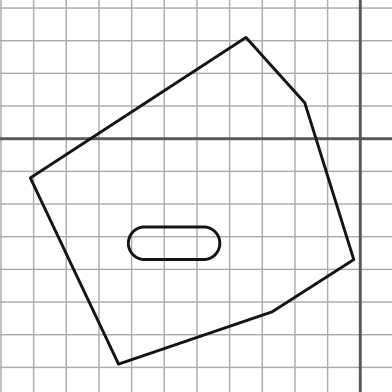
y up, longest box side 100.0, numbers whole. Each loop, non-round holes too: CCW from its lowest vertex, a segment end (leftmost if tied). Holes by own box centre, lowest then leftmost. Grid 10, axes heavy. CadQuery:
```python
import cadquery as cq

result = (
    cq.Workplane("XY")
    .moveTo(-74.0, -69.0)
    .lineTo(-27.0, -53.0)
    .lineTo(-2.0, -37.0)
    .lineTo(-17.0, 11.0)
    .lineTo(-35.0, 31.0)
    .lineTo(-101.0, -12.0)
    .close()
    .moveTo(-66.0, -37.0)
    .lineTo(-48.0, -37.0)
    .threePointArc((-43.0, -32.0), (-48.0, -27.0))
    .lineTo(-66.0, -27.0)
    .threePointArc((-71.0, -32.0), (-66.0, -37.0))
    .close()
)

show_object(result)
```